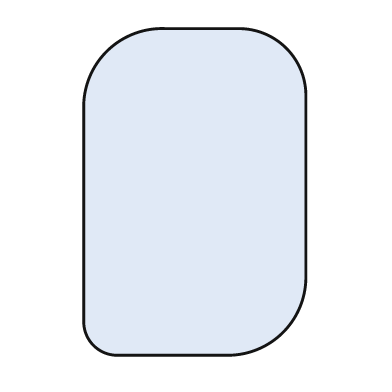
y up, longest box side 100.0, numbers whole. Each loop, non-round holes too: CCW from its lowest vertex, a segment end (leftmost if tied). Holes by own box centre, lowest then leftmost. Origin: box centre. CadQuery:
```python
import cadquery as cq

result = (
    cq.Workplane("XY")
    .moveTo(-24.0, -50.0)
    .lineTo(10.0, -50.0)
    .threePointArc((27.0, -43.0), (34.0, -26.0))
    .lineTo(34.0, 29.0)
    .threePointArc((28.0, 44.0), (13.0, 50.0))
    .lineTo(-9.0, 50.0)
    .threePointArc((-27.0, 43.0), (-34.0, 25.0))
    .lineTo(-34.0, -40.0)
    .threePointArc((-31.0, -47.0), (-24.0, -50.0))
    .close()
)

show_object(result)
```